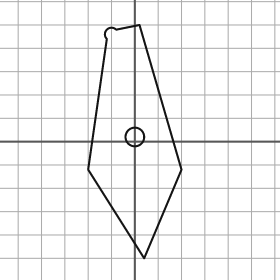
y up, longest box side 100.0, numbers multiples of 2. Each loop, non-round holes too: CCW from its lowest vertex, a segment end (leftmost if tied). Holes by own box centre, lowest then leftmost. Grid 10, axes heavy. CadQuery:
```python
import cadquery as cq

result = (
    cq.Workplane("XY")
    .moveTo(4.0, -50.0)
    .lineTo(20.0, -12.0)
    .lineTo(2.0, 50.0)
    .lineTo(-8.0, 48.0)
    .threePointArc((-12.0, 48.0), (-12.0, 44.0))
    .lineTo(-20.0, -12.0)
    .close()
    .moveTo(0.0, 2.0)
    .circle(4.0)
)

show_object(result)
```